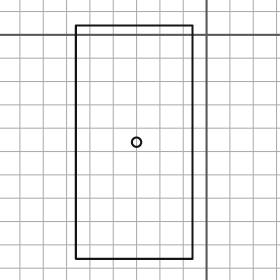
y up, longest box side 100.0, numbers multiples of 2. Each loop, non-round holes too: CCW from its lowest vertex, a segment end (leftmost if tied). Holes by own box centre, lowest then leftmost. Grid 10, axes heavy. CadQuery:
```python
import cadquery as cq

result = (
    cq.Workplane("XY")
    .moveTo(-56.0, -96.0)
    .lineTo(-6.0, -96.0)
    .lineTo(-6.0, 4.0)
    .lineTo(-56.0, 4.0)
    .close()
    .moveTo(-30.0, -46.0)
    .circle(2.0)
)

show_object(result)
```